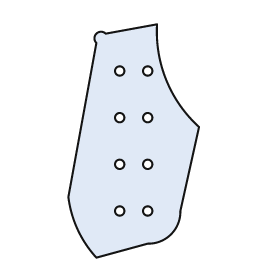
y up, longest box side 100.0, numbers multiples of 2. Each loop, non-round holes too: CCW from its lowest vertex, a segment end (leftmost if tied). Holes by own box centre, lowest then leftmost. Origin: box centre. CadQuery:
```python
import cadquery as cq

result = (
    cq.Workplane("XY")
    .moveTo(-16.0, -50.0)
    .lineTo(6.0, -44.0)
    .threePointArc((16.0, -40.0), (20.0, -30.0))
    .lineTo(28.0, 6.0)
    .threePointArc((14.0, 26.0), (10.0, 50.0))
    .lineTo(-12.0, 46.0)
    .threePointArc((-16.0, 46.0), (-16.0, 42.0))
    .lineTo(-28.0, -24.0)
    .threePointArc((-24.0, -38.0), (-16.0, -50.0))
    .close()
    .moveTo(-6.0, -30.0)
    .circle(2.0)
    .moveTo(6.0, -30.0)
    .circle(2.0)
    .moveTo(-6.0, -10.0)
    .circle(2.0)
    .moveTo(6.0, -10.0)
    .circle(2.0)
    .moveTo(-6.0, 10.0)
    .circle(2.0)
    .moveTo(6.0, 10.0)
    .circle(2.0)
    .moveTo(-6.0, 30.0)
    .circle(2.0)
    .moveTo(6.0, 30.0)
    .circle(2.0)
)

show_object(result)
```